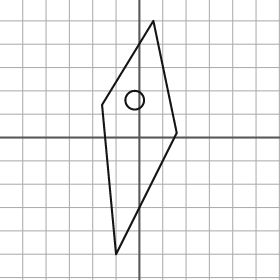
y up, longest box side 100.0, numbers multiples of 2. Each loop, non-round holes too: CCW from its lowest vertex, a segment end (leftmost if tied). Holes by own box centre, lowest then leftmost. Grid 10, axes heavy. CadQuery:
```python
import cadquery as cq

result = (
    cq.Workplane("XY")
    .moveTo(-10.0, -50.0)
    .lineTo(16.0, 2.0)
    .lineTo(6.0, 50.0)
    .lineTo(-16.0, 14.0)
    .close()
    .moveTo(-2.0, 16.0)
    .circle(4.0)
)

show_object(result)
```